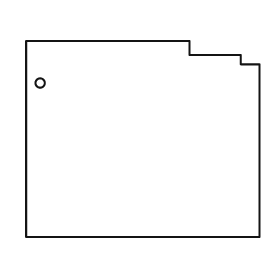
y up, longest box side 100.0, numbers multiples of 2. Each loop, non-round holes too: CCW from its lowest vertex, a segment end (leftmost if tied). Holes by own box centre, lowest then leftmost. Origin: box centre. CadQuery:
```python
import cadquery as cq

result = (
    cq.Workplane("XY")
    .moveTo(-50.0, -42.0)
    .lineTo(50.0, -42.0)
    .lineTo(50.0, 32.0)
    .lineTo(42.0, 32.0)
    .lineTo(42.0, 36.0)
    .lineTo(20.0, 36.0)
    .lineTo(20.0, 42.0)
    .lineTo(-50.0, 42.0)
    .close()
    .moveTo(-44.0, 24.0)
    .circle(2.0)
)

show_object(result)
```